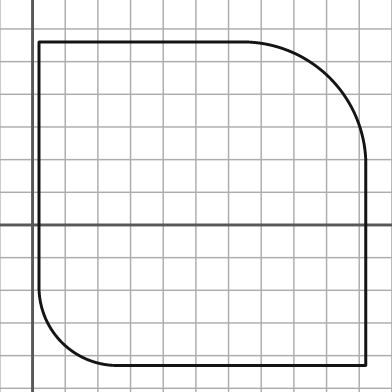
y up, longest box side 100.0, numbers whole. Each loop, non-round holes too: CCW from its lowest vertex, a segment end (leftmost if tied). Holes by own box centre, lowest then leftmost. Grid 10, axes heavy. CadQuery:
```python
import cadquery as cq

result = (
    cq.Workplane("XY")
    .moveTo(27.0, -43.0)
    .lineTo(102.0, -43.0)
    .lineTo(102.0, 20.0)
    .threePointArc((91.0, 45.0), (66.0, 56.0))
    .lineTo(2.0, 56.0)
    .lineTo(2.0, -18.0)
    .threePointArc((9.0, -36.0), (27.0, -43.0))
    .close()
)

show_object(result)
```